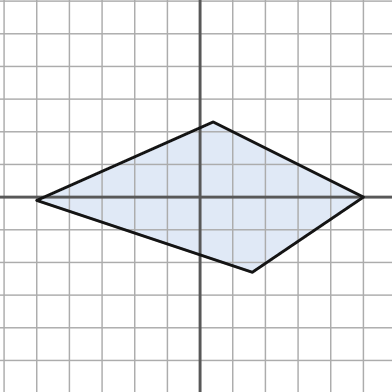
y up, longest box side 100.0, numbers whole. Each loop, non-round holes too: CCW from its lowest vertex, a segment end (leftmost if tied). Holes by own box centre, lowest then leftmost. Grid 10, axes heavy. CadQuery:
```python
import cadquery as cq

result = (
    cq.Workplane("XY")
    .moveTo(16.0, -23.0)
    .lineTo(50.0, 0.0)
    .lineTo(4.0, 23.0)
    .lineTo(-50.0, -1.0)
    .close()
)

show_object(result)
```